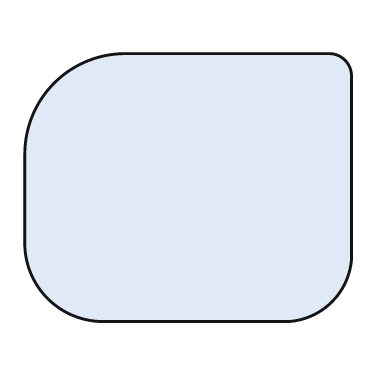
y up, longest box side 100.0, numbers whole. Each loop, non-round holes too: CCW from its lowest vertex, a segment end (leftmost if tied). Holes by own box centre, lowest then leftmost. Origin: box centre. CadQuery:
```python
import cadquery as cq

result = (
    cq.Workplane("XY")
    .moveTo(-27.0, -41.0)
    .lineTo(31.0, -41.0)
    .threePointArc((44.0, -35.0), (50.0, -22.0))
    .lineTo(50.0, 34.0)
    .threePointArc((48.0, 39.0), (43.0, 41.0))
    .lineTo(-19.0, 41.0)
    .threePointArc((-41.0, 32.0), (-50.0, 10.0))
    .lineTo(-50.0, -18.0)
    .threePointArc((-43.0, -34.0), (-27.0, -41.0))
    .close()
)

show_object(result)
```